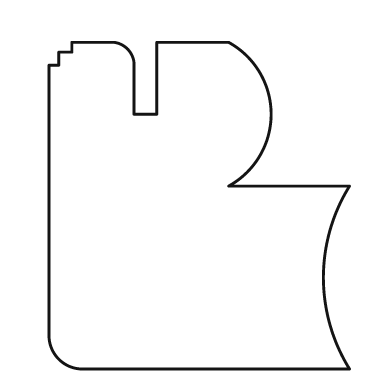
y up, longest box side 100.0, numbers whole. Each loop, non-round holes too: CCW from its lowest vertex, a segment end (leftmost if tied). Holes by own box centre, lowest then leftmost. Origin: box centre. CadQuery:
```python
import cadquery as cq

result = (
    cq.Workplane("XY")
    .moveTo(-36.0, -50.0)
    .lineTo(46.0, -50.0)
    .threePointArc((38.0, -22.0), (46.0, 6.0))
    .lineTo(9.0, 6.0)
    .threePointArc((22.0, 28.0), (9.0, 50.0))
    .lineTo(-13.0, 50.0)
    .lineTo(-13.0, 28.0)
    .lineTo(-20.0, 28.0)
    .lineTo(-20.0, 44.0)
    .threePointArc((-22.0, 48.0), (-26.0, 50.0))
    .lineTo(-39.0, 50.0)
    .lineTo(-39.0, 47.0)
    .lineTo(-43.0, 47.0)
    .lineTo(-43.0, 43.0)
    .lineTo(-46.0, 43.0)
    .lineTo(-46.0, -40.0)
    .threePointArc((-43.0, -47.0), (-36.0, -50.0))
    .close()
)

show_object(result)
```